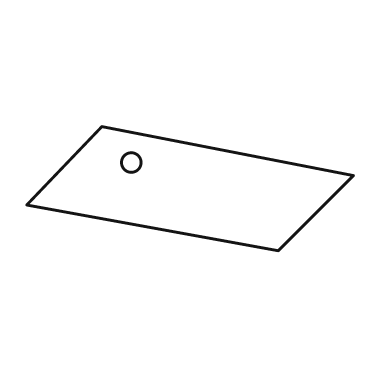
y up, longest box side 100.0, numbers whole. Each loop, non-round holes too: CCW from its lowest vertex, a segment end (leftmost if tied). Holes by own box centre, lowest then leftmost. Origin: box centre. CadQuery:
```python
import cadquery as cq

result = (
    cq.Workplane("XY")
    .moveTo(27.0, -19.0)
    .lineTo(50.0, 4.0)
    .lineTo(-27.0, 19.0)
    .lineTo(-50.0, -5.0)
    .close()
    .moveTo(-18.0, 8.0)
    .circle(3.0)
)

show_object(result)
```